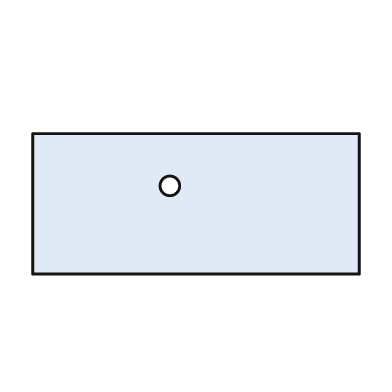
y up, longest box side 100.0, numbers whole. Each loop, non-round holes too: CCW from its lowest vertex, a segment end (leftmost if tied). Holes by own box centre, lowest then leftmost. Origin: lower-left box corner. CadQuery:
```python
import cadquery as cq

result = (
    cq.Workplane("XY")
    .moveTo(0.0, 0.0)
    .lineTo(100.0, 0.0)
    .lineTo(100.0, 43.0)
    .lineTo(0.0, 43.0)
    .close()
    .moveTo(42.0, 27.0)
    .circle(3.0)
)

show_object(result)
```